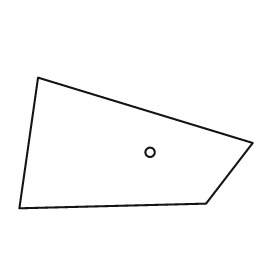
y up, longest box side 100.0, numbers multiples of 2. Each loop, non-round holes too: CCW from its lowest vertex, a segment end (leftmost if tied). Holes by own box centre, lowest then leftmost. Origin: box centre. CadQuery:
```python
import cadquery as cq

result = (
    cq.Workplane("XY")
    .moveTo(-50.0, -28.0)
    .lineTo(30.0, -26.0)
    .lineTo(50.0, 0.0)
    .lineTo(-42.0, 28.0)
    .close()
    .moveTo(6.0, -4.0)
    .circle(2.0)
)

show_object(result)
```